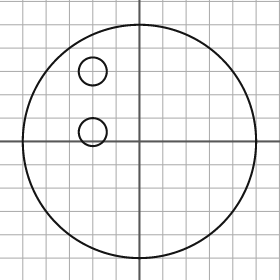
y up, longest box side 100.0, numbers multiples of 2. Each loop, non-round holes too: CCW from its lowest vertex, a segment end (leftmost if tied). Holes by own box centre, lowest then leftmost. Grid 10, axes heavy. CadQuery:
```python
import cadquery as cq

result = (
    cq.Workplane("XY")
    .moveTo(0.0, 0.0)
    .circle(50.0)
    .moveTo(-20.0, 4.0)
    .circle(6.0)
    .moveTo(-20.0, 30.0)
    .circle(6.0)
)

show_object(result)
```